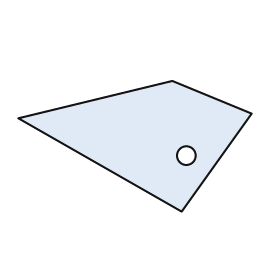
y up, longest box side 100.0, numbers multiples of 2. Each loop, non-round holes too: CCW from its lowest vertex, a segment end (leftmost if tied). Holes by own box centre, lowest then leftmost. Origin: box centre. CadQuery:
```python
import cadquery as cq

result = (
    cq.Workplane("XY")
    .moveTo(20.0, -28.0)
    .lineTo(50.0, 14.0)
    .lineTo(16.0, 28.0)
    .lineTo(-50.0, 12.0)
    .close()
    .moveTo(22.0, -4.0)
    .circle(4.0)
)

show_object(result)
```